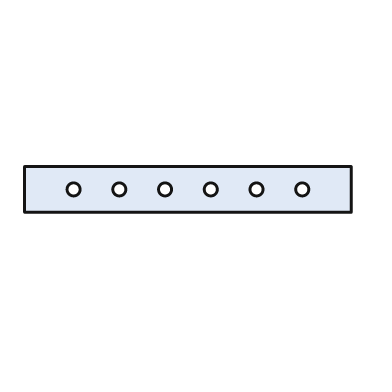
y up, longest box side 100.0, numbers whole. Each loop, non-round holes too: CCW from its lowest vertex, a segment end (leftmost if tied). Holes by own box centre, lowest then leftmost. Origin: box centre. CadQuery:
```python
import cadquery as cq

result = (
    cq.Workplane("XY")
    .moveTo(-50.0, -7.0)
    .lineTo(50.0, -7.0)
    .lineTo(50.0, 7.0)
    .lineTo(-50.0, 7.0)
    .close()
    .moveTo(-35.0, 0.0)
    .circle(2.0)
    .moveTo(-21.0, 0.0)
    .circle(2.0)
    .moveTo(-7.0, 0.0)
    .circle(2.0)
    .moveTo(7.0, 0.0)
    .circle(2.0)
    .moveTo(21.0, 0.0)
    .circle(2.0)
    .moveTo(35.0, 0.0)
    .circle(2.0)
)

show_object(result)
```